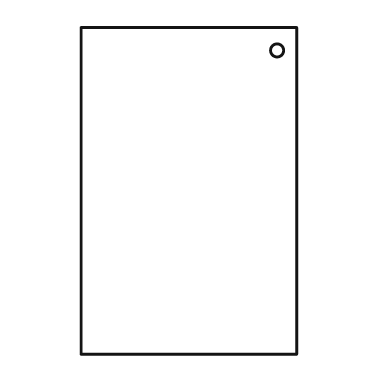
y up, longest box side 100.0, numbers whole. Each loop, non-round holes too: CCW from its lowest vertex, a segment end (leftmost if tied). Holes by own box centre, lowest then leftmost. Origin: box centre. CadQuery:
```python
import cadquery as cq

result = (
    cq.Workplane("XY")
    .moveTo(-33.0, -50.0)
    .lineTo(33.0, -50.0)
    .lineTo(33.0, 50.0)
    .lineTo(-33.0, 50.0)
    .close()
    .moveTo(27.0, 43.0)
    .circle(2.0)
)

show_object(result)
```